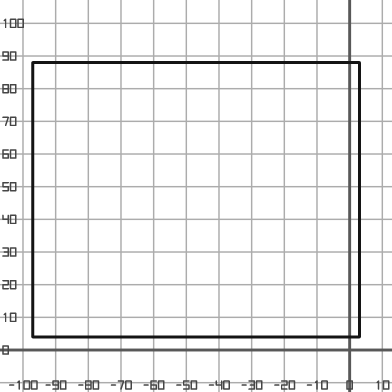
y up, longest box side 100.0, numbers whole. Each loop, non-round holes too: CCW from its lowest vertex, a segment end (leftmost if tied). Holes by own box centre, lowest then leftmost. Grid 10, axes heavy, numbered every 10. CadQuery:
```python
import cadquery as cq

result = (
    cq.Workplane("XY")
    .moveTo(-97.0, 4.0)
    .lineTo(3.0, 4.0)
    .lineTo(3.0, 88.0)
    .lineTo(-97.0, 88.0)
    .close()
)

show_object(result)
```